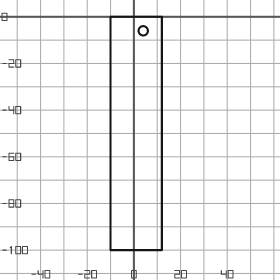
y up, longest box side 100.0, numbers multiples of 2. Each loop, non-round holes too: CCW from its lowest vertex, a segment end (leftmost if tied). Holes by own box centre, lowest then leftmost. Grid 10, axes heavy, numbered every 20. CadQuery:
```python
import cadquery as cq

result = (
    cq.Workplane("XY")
    .moveTo(-10.0, -100.0)
    .lineTo(12.0, -100.0)
    .lineTo(12.0, 0.0)
    .lineTo(-10.0, 0.0)
    .close()
    .moveTo(4.0, -6.0)
    .circle(2.0)
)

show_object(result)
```